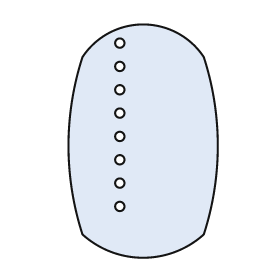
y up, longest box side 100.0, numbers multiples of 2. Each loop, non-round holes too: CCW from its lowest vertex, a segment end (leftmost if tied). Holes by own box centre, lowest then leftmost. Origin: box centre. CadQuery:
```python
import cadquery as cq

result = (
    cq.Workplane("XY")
    .moveTo(-26.0, -40.0)
    .threePointArc((0.0, -50.0), (26.0, -40.0))
    .threePointArc((32.0, -2.0), (26.0, 36.0))
    .threePointArc((0.0, 50.0), (-26.0, 36.0))
    .threePointArc((-32.0, -2.0), (-26.0, -40.0))
    .close()
    .moveTo(-10.0, -28.0)
    .circle(2.0)
    .moveTo(-10.0, -18.0)
    .circle(2.0)
    .moveTo(-10.0, -8.0)
    .circle(2.0)
    .moveTo(-10.0, 2.0)
    .circle(2.0)
    .moveTo(-10.0, 12.0)
    .circle(2.0)
    .moveTo(-10.0, 22.0)
    .circle(2.0)
    .moveTo(-10.0, 32.0)
    .circle(2.0)
    .moveTo(-10.0, 42.0)
    .circle(2.0)
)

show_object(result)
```